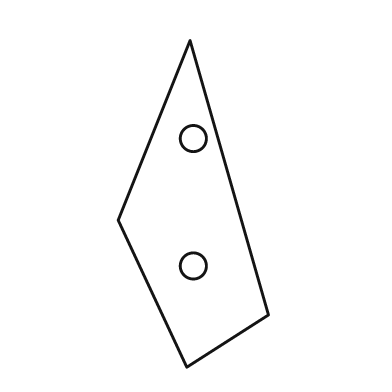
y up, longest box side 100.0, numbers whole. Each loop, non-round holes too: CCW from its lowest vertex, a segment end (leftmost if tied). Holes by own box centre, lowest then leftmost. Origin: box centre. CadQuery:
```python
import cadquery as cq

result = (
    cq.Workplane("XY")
    .moveTo(-2.0, -50.0)
    .lineTo(23.0, -34.0)
    .lineTo(-1.0, 50.0)
    .lineTo(-23.0, -5.0)
    .close()
    .moveTo(0.0, -19.0)
    .circle(4.0)
    .moveTo(0.0, 20.0)
    .circle(4.0)
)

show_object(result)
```